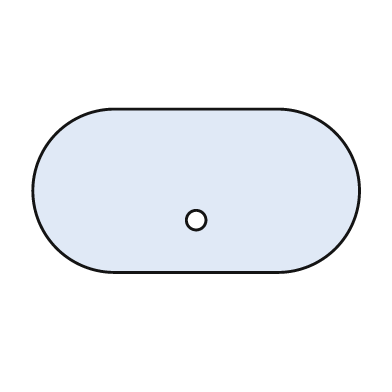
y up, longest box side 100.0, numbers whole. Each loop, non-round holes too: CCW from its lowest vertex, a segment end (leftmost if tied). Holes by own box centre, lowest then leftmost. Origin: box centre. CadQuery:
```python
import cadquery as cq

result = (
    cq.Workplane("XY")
    .moveTo(-25.0, -25.0)
    .lineTo(25.0, -25.0)
    .threePointArc((50.0, 0.0), (25.0, 25.0))
    .lineTo(-25.0, 25.0)
    .threePointArc((-50.0, 0.0), (-25.0, -25.0))
    .close()
    .moveTo(0.0, -9.0)
    .circle(3.0)
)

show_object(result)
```